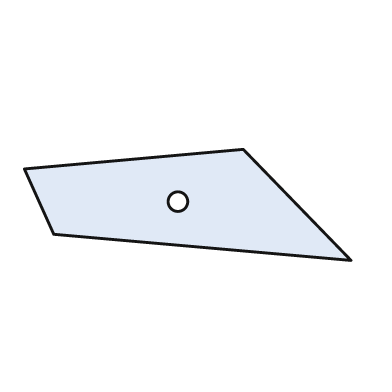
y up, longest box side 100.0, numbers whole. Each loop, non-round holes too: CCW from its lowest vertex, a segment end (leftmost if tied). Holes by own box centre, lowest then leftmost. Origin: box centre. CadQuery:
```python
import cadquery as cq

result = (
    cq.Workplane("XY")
    .moveTo(50.0, -17.0)
    .lineTo(17.0, 17.0)
    .lineTo(-50.0, 11.0)
    .lineTo(-41.0, -9.0)
    .close()
    .moveTo(-3.0, 1.0)
    .circle(3.0)
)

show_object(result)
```